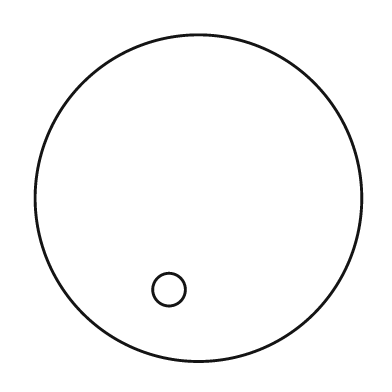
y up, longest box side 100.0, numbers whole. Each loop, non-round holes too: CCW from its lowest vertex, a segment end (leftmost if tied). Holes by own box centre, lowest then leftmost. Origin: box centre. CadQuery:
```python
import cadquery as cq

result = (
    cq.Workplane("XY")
    .moveTo(0.0, 0.0)
    .circle(50.0)
    .moveTo(-9.0, -28.0)
    .circle(5.0)
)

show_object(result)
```